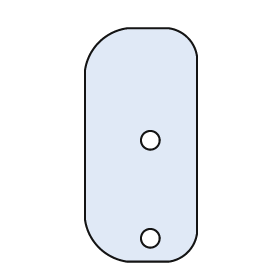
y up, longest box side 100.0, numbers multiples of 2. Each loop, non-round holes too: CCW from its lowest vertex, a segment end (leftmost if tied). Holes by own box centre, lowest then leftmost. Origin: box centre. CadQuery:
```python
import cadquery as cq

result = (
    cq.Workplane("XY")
    .moveTo(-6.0, -50.0)
    .lineTo(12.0, -50.0)
    .threePointArc((20.0, -46.0), (24.0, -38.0))
    .lineTo(24.0, 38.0)
    .threePointArc((20.0, 46.0), (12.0, 50.0))
    .lineTo(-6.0, 50.0)
    .threePointArc((-18.0, 44.0), (-24.0, 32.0))
    .lineTo(-24.0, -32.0)
    .threePointArc((-18.0, -44.0), (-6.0, -50.0))
    .close()
    .moveTo(4.0, -40.0)
    .circle(4.0)
    .moveTo(4.0, 2.0)
    .circle(4.0)
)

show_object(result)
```